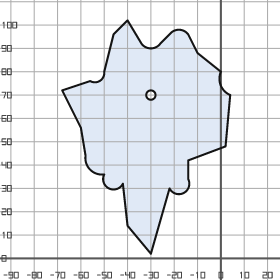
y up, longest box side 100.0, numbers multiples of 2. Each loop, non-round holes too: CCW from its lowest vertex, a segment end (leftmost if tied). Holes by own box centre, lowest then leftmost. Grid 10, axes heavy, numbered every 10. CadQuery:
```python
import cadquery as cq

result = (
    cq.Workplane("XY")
    .moveTo(-30.0, 2.0)
    .lineTo(-22.0, 30.0)
    .threePointArc((-16.0, 28.0), (-14.0, 34.0))
    .lineTo(-14.0, 42.0)
    .lineTo(2.0, 48.0)
    .lineTo(4.0, 70.0)
    .threePointArc((0.0, 74.0), (0.0, 80.0))
    .lineTo(-10.0, 88.0)
    .lineTo(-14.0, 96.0)
    .threePointArc((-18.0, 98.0), (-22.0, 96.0))
    .lineTo(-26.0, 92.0)
    .threePointArc((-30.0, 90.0), (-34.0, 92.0))
    .lineTo(-40.0, 102.0)
    .lineTo(-46.0, 96.0)
    .lineTo(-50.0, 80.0)
    .threePointArc((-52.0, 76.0), (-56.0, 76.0))
    .lineTo(-68.0, 72.0)
    .lineTo(-60.0, 56.0)
    .lineTo(-58.0, 44.0)
    .threePointArc((-56.0, 38.0), (-50.0, 36.0))
    .threePointArc((-48.0, 30.0), (-42.0, 32.0))
    .lineTo(-40.0, 14.0)
    .close()
    .moveTo(-30.0, 70.0)
    .circle(2.0)
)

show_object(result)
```